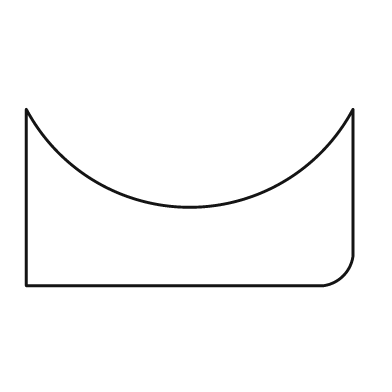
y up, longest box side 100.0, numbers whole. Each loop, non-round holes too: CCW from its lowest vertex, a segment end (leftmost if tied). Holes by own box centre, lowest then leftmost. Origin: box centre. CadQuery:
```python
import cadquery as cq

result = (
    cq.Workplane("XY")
    .moveTo(-50.0, -27.0)
    .lineTo(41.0, -27.0)
    .threePointArc((47.0, -24.0), (50.0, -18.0))
    .lineTo(50.0, 27.0)
    .threePointArc((0.0, -3.0), (-50.0, 27.0))
    .close()
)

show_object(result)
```